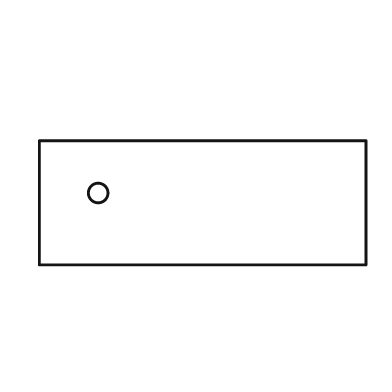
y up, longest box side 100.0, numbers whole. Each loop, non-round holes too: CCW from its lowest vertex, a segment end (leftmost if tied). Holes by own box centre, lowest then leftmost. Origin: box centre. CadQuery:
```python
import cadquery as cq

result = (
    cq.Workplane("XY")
    .moveTo(-50.0, -19.0)
    .lineTo(50.0, -19.0)
    .lineTo(50.0, 19.0)
    .lineTo(-50.0, 19.0)
    .close()
    .moveTo(-32.0, 3.0)
    .circle(3.0)
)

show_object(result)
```